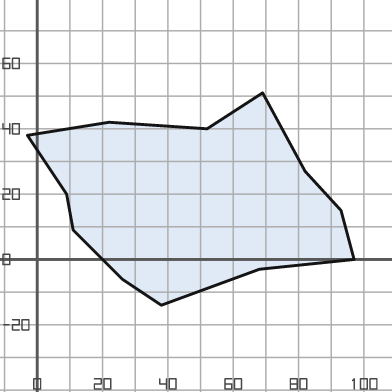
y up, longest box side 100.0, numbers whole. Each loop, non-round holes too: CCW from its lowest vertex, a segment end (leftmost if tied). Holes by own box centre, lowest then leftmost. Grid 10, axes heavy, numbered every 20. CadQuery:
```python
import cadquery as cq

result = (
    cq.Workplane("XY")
    .moveTo(38.0, -14.0)
    .lineTo(68.0, -3.0)
    .lineTo(97.0, 0.0)
    .lineTo(93.0, 15.0)
    .lineTo(82.0, 27.0)
    .lineTo(69.0, 51.0)
    .lineTo(52.0, 40.0)
    .lineTo(22.0, 42.0)
    .lineTo(-3.0, 38.0)
    .lineTo(9.0, 20.0)
    .lineTo(11.0, 9.0)
    .lineTo(26.0, -6.0)
    .close()
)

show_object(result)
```